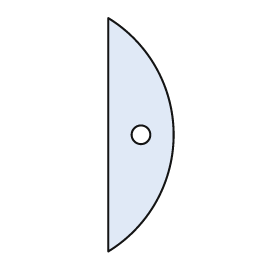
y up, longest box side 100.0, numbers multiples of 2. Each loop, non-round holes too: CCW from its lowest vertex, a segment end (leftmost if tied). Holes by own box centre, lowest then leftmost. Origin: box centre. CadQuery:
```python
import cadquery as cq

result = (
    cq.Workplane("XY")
    .moveTo(-14.0, -50.0)
    .threePointArc((14.0, 0.0), (-14.0, 50.0))
    .close()
    .moveTo(0.0, 0.0)
    .circle(4.0)
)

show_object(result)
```